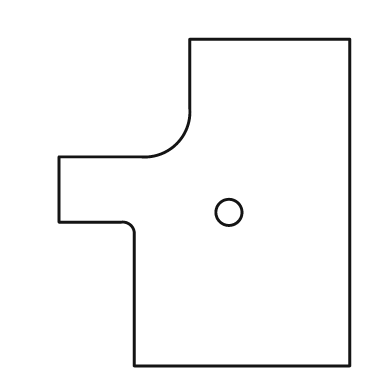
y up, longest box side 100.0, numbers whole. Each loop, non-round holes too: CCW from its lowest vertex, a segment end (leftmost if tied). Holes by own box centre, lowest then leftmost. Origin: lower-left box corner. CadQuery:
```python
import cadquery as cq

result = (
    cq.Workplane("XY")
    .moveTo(23.0, 0.0)
    .lineTo(89.0, 0.0)
    .lineTo(89.0, 100.0)
    .lineTo(40.0, 100.0)
    .lineTo(40.0, 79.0)
    .threePointArc((36.0, 68.0), (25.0, 64.0))
    .lineTo(0.0, 64.0)
    .lineTo(0.0, 44.0)
    .lineTo(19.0, 44.0)
    .threePointArc((22.0, 43.0), (23.0, 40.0))
    .close()
    .moveTo(52.0, 47.0)
    .circle(4.0)
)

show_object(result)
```